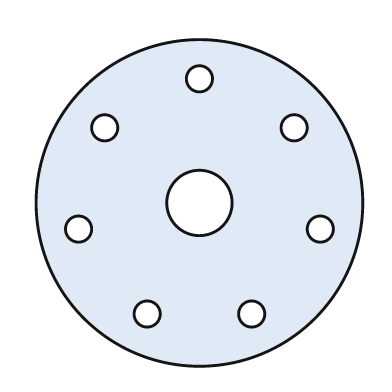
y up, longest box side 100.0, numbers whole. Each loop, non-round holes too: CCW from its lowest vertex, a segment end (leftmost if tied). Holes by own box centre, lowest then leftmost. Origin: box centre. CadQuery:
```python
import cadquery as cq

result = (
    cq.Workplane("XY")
    .moveTo(0.0, 0.0)
    .circle(50.0)
    .moveTo(-16.0, -34.0)
    .circle(4.0)
    .moveTo(16.0, -34.0)
    .circle(4.0)
    .moveTo(-37.0, -8.0)
    .circle(4.0)
    .moveTo(37.0, -8.0)
    .circle(4.0)
    .moveTo(0.0, 0.0)
    .circle(10.0)
    .moveTo(-29.0, 23.0)
    .circle(4.0)
    .moveTo(29.0, 23.0)
    .circle(4.0)
    .moveTo(0.0, 38.0)
    .circle(4.0)
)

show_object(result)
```